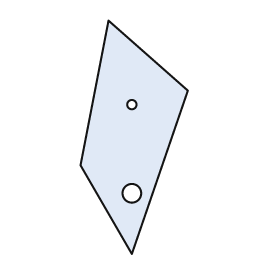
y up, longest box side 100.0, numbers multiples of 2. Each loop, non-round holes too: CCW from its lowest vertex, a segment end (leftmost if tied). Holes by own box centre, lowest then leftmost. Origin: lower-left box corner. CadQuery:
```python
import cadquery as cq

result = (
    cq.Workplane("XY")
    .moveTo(22.0, 0.0)
    .lineTo(46.0, 70.0)
    .lineTo(12.0, 100.0)
    .lineTo(0.0, 38.0)
    .close()
    .moveTo(22.0, 26.0)
    .circle(4.0)
    .moveTo(22.0, 64.0)
    .circle(2.0)
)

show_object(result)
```